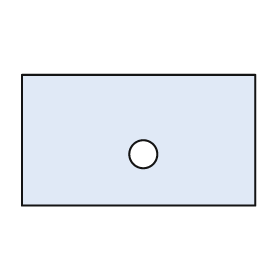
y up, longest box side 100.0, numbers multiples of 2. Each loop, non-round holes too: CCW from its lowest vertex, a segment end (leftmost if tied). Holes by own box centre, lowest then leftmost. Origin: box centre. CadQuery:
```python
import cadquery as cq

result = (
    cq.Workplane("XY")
    .moveTo(-50.0, -28.0)
    .lineTo(50.0, -28.0)
    .lineTo(50.0, 28.0)
    .lineTo(-50.0, 28.0)
    .close()
    .moveTo(2.0, -6.0)
    .circle(6.0)
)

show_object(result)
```